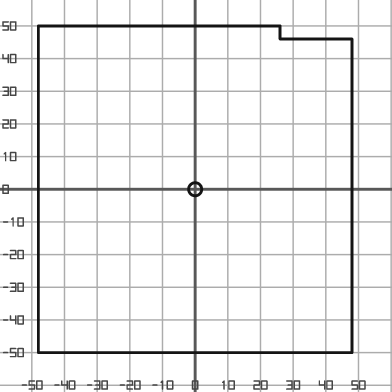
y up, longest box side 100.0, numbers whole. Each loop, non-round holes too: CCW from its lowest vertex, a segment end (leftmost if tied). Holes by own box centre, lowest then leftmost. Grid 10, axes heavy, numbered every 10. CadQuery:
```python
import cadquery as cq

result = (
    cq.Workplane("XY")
    .moveTo(-48.0, -50.0)
    .lineTo(48.0, -50.0)
    .lineTo(48.0, 46.0)
    .lineTo(26.0, 46.0)
    .lineTo(26.0, 50.0)
    .lineTo(-48.0, 50.0)
    .close()
    .moveTo(0.0, 0.0)
    .circle(2.0)
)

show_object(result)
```